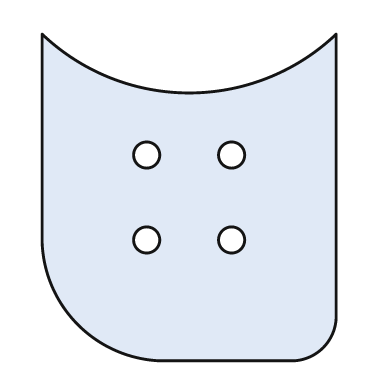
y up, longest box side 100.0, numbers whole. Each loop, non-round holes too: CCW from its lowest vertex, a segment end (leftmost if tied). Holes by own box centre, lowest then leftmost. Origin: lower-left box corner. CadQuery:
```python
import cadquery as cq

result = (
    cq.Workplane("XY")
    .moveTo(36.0, 0.0)
    .lineTo(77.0, 0.0)
    .threePointArc((86.0, 4.0), (90.0, 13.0))
    .lineTo(90.0, 100.0)
    .threePointArc((45.0, 82.0), (0.0, 100.0))
    .lineTo(0.0, 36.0)
    .threePointArc((11.0, 11.0), (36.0, 0.0))
    .close()
    .moveTo(32.0, 37.0)
    .circle(4.0)
    .moveTo(58.0, 37.0)
    .circle(4.0)
    .moveTo(32.0, 63.0)
    .circle(4.0)
    .moveTo(58.0, 63.0)
    .circle(4.0)
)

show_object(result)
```